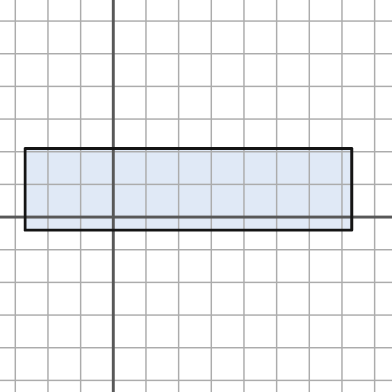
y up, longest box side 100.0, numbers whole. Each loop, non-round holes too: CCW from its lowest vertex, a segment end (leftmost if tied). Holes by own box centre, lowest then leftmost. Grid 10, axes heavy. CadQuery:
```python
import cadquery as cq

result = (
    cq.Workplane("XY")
    .moveTo(-27.0, -4.0)
    .lineTo(73.0, -4.0)
    .lineTo(73.0, 21.0)
    .lineTo(-27.0, 21.0)
    .close()
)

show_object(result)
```